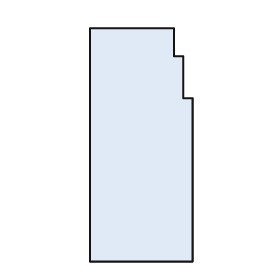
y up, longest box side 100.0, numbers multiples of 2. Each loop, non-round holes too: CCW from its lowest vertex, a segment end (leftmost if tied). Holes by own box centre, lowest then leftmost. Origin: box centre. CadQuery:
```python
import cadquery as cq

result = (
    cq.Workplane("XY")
    .moveTo(-22.0, -50.0)
    .lineTo(22.0, -50.0)
    .lineTo(22.0, 20.0)
    .lineTo(18.0, 20.0)
    .lineTo(18.0, 38.0)
    .lineTo(14.0, 38.0)
    .lineTo(14.0, 50.0)
    .lineTo(-22.0, 50.0)
    .close()
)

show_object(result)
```